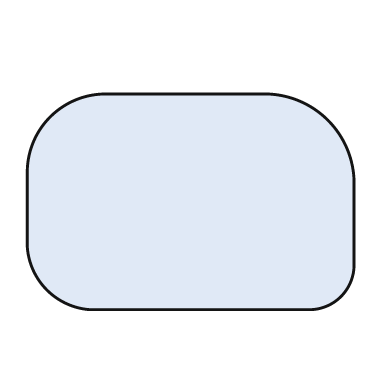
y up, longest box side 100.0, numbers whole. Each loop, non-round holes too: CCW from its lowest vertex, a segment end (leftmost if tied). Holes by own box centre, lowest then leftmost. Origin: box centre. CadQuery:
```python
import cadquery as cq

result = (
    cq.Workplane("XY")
    .moveTo(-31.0, -33.0)
    .lineTo(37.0, -33.0)
    .threePointArc((46.0, -29.0), (50.0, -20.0))
    .lineTo(50.0, 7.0)
    .threePointArc((42.0, 25.0), (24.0, 33.0))
    .lineTo(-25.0, 33.0)
    .threePointArc((-43.0, 26.0), (-50.0, 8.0))
    .lineTo(-50.0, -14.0)
    .threePointArc((-44.0, -27.0), (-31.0, -33.0))
    .close()
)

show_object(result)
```